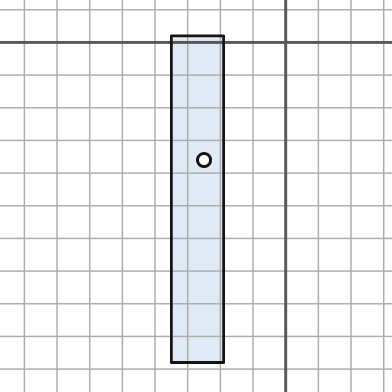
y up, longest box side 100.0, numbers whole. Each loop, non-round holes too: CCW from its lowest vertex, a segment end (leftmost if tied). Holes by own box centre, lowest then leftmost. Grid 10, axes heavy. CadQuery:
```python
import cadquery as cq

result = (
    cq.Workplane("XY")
    .moveTo(-35.0, -98.0)
    .lineTo(-19.0, -98.0)
    .lineTo(-19.0, 2.0)
    .lineTo(-35.0, 2.0)
    .close()
    .moveTo(-25.0, -36.0)
    .circle(2.0)
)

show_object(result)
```